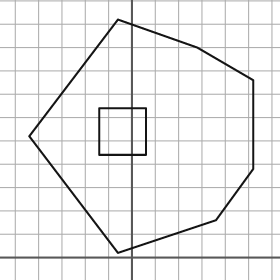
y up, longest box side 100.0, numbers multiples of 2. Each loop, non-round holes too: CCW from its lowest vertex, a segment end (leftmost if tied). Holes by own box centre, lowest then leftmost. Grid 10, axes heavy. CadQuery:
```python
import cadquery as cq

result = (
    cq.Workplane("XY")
    .moveTo(-6.0, 2.0)
    .lineTo(36.0, 16.0)
    .lineTo(52.0, 38.0)
    .lineTo(52.0, 76.0)
    .lineTo(28.0, 90.0)
    .lineTo(-6.0, 102.0)
    .lineTo(-44.0, 52.0)
    .close()
    .moveTo(-14.0, 44.0)
    .lineTo(6.0, 44.0)
    .lineTo(6.0, 64.0)
    .lineTo(-14.0, 64.0)
    .close()
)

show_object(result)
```